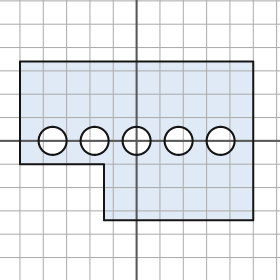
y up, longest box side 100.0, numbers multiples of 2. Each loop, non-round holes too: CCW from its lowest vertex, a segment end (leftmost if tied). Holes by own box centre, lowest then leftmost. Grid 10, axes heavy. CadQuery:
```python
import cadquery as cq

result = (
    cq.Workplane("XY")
    .moveTo(-14.0, -34.0)
    .lineTo(50.0, -34.0)
    .lineTo(50.0, 34.0)
    .lineTo(-50.0, 34.0)
    .lineTo(-50.0, -10.0)
    .lineTo(-14.0, -10.0)
    .close()
    .moveTo(-36.0, 0.0)
    .circle(6.0)
    .moveTo(-18.0, 0.0)
    .circle(6.0)
    .moveTo(0.0, 0.0)
    .circle(6.0)
    .moveTo(18.0, 0.0)
    .circle(6.0)
    .moveTo(36.0, 0.0)
    .circle(6.0)
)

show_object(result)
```